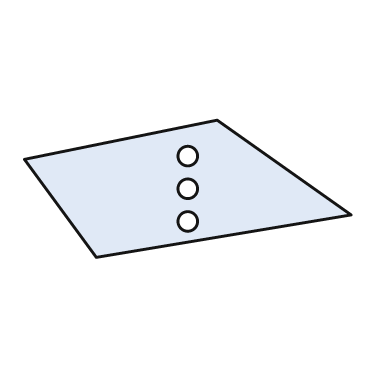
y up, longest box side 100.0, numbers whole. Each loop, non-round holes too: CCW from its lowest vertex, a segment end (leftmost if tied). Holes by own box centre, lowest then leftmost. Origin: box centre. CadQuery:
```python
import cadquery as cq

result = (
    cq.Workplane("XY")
    .moveTo(-28.0, -21.0)
    .lineTo(50.0, -8.0)
    .lineTo(9.0, 21.0)
    .lineTo(-50.0, 9.0)
    .close()
    .moveTo(0.0, -10.0)
    .circle(3.0)
    .moveTo(0.0, 0.0)
    .circle(3.0)
    .moveTo(0.0, 10.0)
    .circle(3.0)
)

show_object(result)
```